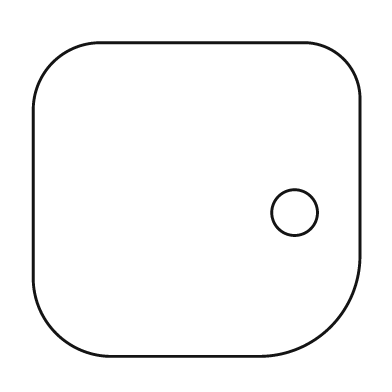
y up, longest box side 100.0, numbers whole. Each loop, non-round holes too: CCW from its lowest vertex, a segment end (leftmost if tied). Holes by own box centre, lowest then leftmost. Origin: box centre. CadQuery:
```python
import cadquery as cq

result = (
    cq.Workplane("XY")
    .moveTo(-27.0, -48.0)
    .lineTo(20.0, -48.0)
    .threePointArc((41.0, -39.0), (50.0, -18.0))
    .lineTo(50.0, 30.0)
    .threePointArc((45.0, 43.0), (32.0, 48.0))
    .lineTo(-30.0, 48.0)
    .threePointArc((-44.0, 42.0), (-50.0, 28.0))
    .lineTo(-50.0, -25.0)
    .threePointArc((-43.0, -41.0), (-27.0, -48.0))
    .close()
    .moveTo(30.0, -4.0)
    .circle(7.0)
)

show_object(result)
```